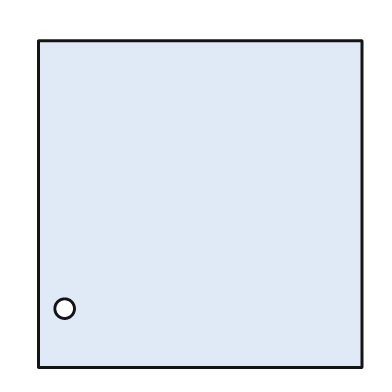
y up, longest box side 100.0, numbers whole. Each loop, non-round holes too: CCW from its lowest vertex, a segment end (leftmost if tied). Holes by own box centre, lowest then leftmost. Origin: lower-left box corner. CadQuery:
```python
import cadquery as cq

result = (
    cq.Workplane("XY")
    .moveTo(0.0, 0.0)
    .lineTo(99.0, 0.0)
    .lineTo(99.0, 100.0)
    .lineTo(0.0, 100.0)
    .close()
    .moveTo(8.0, 18.0)
    .circle(3.0)
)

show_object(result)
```